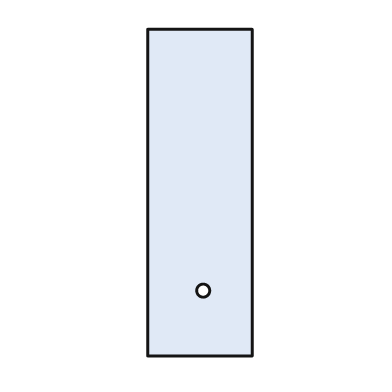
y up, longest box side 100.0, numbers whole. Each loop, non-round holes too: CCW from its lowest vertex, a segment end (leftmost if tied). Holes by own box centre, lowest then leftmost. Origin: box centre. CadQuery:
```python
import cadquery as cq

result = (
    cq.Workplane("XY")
    .moveTo(-16.0, -50.0)
    .lineTo(16.0, -50.0)
    .lineTo(16.0, 50.0)
    .lineTo(-16.0, 50.0)
    .close()
    .moveTo(1.0, -30.0)
    .circle(2.0)
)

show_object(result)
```